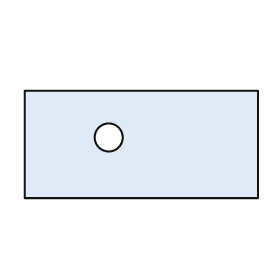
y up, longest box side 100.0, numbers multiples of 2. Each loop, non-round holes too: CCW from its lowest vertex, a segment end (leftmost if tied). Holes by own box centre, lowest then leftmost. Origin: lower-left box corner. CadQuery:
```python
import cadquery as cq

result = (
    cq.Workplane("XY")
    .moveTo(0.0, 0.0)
    .lineTo(100.0, 0.0)
    .lineTo(100.0, 46.0)
    .lineTo(0.0, 46.0)
    .close()
    .moveTo(36.0, 26.0)
    .circle(6.0)
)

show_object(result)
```